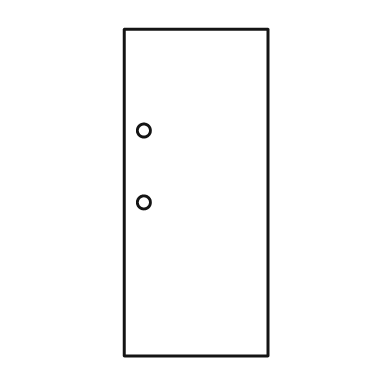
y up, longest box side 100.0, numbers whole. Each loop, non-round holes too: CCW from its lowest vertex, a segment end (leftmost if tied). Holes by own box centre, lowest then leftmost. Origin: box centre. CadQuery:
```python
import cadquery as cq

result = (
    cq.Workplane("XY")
    .moveTo(-22.0, -50.0)
    .lineTo(22.0, -50.0)
    .lineTo(22.0, 50.0)
    .lineTo(-22.0, 50.0)
    .close()
    .moveTo(-16.0, -3.0)
    .circle(2.0)
    .moveTo(-16.0, 19.0)
    .circle(2.0)
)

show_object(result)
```